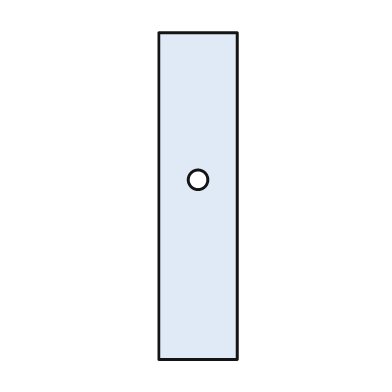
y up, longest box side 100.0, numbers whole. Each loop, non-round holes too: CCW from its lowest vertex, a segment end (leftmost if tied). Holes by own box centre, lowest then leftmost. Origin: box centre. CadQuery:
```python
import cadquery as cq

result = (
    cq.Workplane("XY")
    .moveTo(-12.0, -50.0)
    .lineTo(12.0, -50.0)
    .lineTo(12.0, 50.0)
    .lineTo(-12.0, 50.0)
    .close()
    .moveTo(0.0, 5.0)
    .circle(3.0)
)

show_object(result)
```